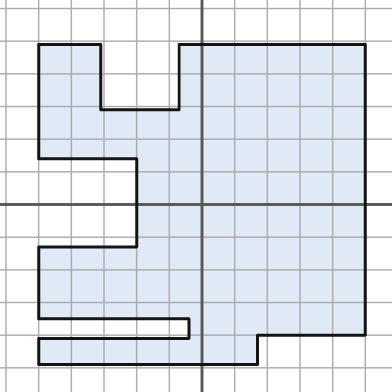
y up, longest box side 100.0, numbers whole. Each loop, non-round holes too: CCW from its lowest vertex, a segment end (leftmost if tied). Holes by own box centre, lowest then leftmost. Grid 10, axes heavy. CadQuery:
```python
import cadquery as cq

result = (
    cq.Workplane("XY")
    .moveTo(-50.0, -49.0)
    .lineTo(17.0, -49.0)
    .lineTo(17.0, -40.0)
    .lineTo(50.0, -40.0)
    .lineTo(50.0, 49.0)
    .lineTo(-7.0, 49.0)
    .lineTo(-7.0, 29.0)
    .lineTo(-31.0, 29.0)
    .lineTo(-31.0, 49.0)
    .lineTo(-50.0, 49.0)
    .lineTo(-50.0, 14.0)
    .lineTo(-20.0, 14.0)
    .lineTo(-20.0, -13.0)
    .lineTo(-50.0, -13.0)
    .lineTo(-50.0, -35.0)
    .lineTo(-4.0, -35.0)
    .lineTo(-4.0, -41.0)
    .lineTo(-50.0, -41.0)
    .close()
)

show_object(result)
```